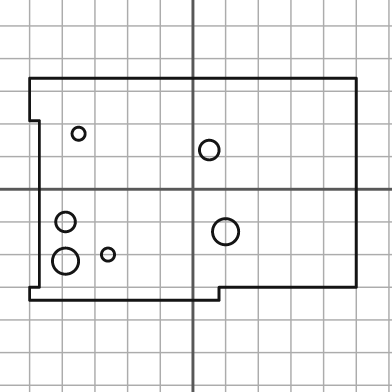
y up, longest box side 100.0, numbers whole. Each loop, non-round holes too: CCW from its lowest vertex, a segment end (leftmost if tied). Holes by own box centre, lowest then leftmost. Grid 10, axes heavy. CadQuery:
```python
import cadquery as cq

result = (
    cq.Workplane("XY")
    .moveTo(-50.0, -34.0)
    .lineTo(8.0, -34.0)
    .lineTo(8.0, -30.0)
    .lineTo(50.0, -30.0)
    .lineTo(50.0, 34.0)
    .lineTo(-50.0, 34.0)
    .lineTo(-50.0, 21.0)
    .lineTo(-47.0, 21.0)
    .lineTo(-47.0, -30.0)
    .lineTo(-50.0, -30.0)
    .close()
    .moveTo(-39.0, -22.0)
    .circle(4.0)
    .moveTo(-26.0, -20.0)
    .circle(2.0)
    .moveTo(10.0, -13.0)
    .circle(4.0)
    .moveTo(-39.0, -10.0)
    .circle(3.0)
    .moveTo(5.0, 12.0)
    .circle(3.0)
    .moveTo(-35.0, 17.0)
    .circle(2.0)
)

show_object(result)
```